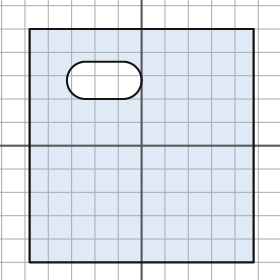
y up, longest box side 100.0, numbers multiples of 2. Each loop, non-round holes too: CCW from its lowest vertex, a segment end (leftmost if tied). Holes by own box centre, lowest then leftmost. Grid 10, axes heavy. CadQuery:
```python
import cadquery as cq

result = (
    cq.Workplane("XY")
    .moveTo(-48.0, -50.0)
    .lineTo(48.0, -50.0)
    .lineTo(48.0, 50.0)
    .lineTo(-48.0, 50.0)
    .close()
    .moveTo(-24.0, 20.0)
    .lineTo(-8.0, 20.0)
    .threePointArc((0.0, 28.0), (-8.0, 36.0))
    .lineTo(-24.0, 36.0)
    .threePointArc((-32.0, 28.0), (-24.0, 20.0))
    .close()
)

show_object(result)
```